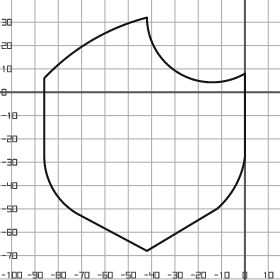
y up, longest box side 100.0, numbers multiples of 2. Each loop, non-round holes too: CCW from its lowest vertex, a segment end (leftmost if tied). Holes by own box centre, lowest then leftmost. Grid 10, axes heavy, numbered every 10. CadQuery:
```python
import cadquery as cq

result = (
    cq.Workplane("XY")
    .moveTo(-42.0, -68.0)
    .lineTo(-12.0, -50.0)
    .threePointArc((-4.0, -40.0), (0.0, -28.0))
    .lineTo(0.0, 8.0)
    .threePointArc((-28.0, 8.0), (-42.0, 32.0))
    .threePointArc((-66.0, 22.0), (-86.0, 6.0))
    .lineTo(-86.0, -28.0)
    .threePointArc((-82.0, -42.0), (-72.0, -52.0))
    .close()
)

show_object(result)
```